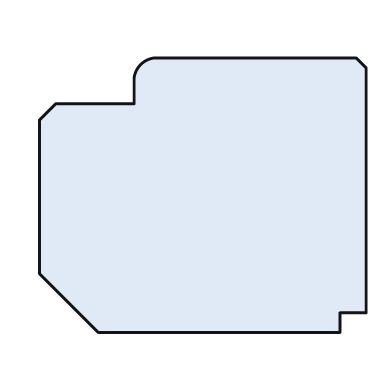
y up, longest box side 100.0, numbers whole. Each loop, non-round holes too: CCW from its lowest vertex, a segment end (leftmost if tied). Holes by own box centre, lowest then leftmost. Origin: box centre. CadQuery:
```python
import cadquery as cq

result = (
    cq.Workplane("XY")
    .moveTo(-32.0, -42.0)
    .lineTo(42.0, -42.0)
    .lineTo(42.0, -36.0)
    .lineTo(50.0, -36.0)
    .lineTo(50.0, 39.0)
    .lineTo(47.0, 42.0)
    .lineTo(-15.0, 42.0)
    .threePointArc((-19.0, 40.0), (-21.0, 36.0))
    .lineTo(-21.0, 28.0)
    .lineTo(-45.0, 28.0)
    .lineTo(-50.0, 23.0)
    .lineTo(-50.0, -24.0)
    .close()
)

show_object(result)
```